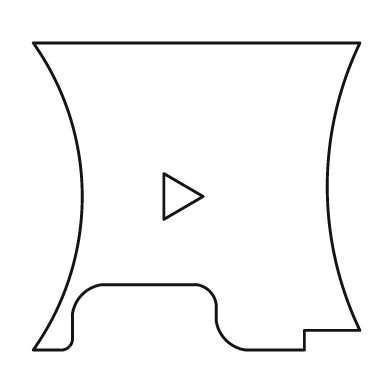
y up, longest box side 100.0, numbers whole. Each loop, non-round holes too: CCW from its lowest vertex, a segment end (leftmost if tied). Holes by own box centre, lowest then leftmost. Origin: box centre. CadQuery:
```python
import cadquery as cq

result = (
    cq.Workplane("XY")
    .moveTo(-50.0, -47.0)
    .lineTo(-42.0, -47.0)
    .threePointArc((-39.0, -46.0), (-38.0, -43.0))
    .lineTo(-38.0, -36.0)
    .threePointArc((-35.0, -30.0), (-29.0, -27.0))
    .lineTo(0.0, -27.0)
    .threePointArc((4.0, -29.0), (6.0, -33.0))
    .lineTo(6.0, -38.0)
    .threePointArc((9.0, -44.0), (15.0, -47.0))
    .lineTo(33.0, -47.0)
    .lineTo(33.0, -41.0)
    .lineTo(50.0, -41.0)
    .threePointArc((40.0, 3.0), (50.0, 47.0))
    .lineTo(-50.0, 47.0)
    .threePointArc((-35.0, 0.0), (-50.0, -47.0))
    .close()
    .moveTo(-10.0, -7.0)
    .lineTo(2.0, 0.0)
    .lineTo(-10.0, 7.0)
    .close()
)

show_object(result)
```